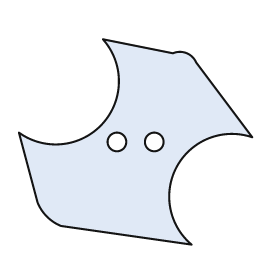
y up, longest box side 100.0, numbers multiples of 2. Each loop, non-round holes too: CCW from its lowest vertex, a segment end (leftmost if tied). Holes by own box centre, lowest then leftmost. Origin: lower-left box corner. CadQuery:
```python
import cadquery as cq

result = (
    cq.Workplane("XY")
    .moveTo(74.0, 0.0)
    .threePointArc((68.0, 34.0), (100.0, 46.0))
    .lineTo(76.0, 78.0)
    .threePointArc((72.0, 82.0), (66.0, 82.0))
    .lineTo(36.0, 88.0)
    .threePointArc((36.0, 52.0), (0.0, 48.0))
    .lineTo(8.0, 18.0)
    .threePointArc((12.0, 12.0), (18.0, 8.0))
    .close()
    .moveTo(42.0, 44.0)
    .circle(4.0)
    .moveTo(58.0, 44.0)
    .circle(4.0)
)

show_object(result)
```